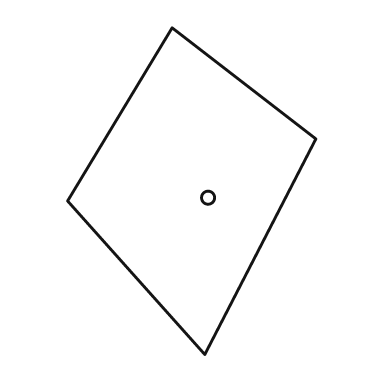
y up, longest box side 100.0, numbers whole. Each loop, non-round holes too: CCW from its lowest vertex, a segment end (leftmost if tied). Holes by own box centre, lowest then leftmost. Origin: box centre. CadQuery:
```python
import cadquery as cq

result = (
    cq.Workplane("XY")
    .moveTo(4.0, -50.0)
    .lineTo(38.0, 16.0)
    .lineTo(-6.0, 50.0)
    .lineTo(-38.0, -3.0)
    .close()
    .moveTo(5.0, -2.0)
    .circle(2.0)
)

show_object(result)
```